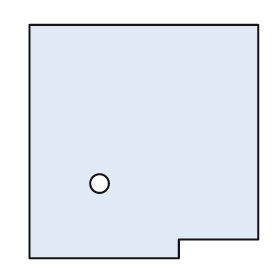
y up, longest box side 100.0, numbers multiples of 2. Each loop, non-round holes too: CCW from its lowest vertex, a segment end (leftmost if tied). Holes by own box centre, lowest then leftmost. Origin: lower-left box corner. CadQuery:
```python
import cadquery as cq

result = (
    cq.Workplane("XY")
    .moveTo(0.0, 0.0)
    .lineTo(64.0, 0.0)
    .lineTo(64.0, 8.0)
    .lineTo(98.0, 8.0)
    .lineTo(98.0, 100.0)
    .lineTo(0.0, 100.0)
    .close()
    .moveTo(30.0, 32.0)
    .circle(4.0)
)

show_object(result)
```